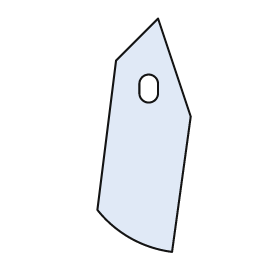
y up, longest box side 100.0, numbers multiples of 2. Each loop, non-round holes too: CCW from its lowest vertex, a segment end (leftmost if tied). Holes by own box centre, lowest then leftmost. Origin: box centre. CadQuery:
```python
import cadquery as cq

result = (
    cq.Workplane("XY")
    .moveTo(12.0, -50.0)
    .lineTo(20.0, 8.0)
    .lineTo(6.0, 50.0)
    .lineTo(-12.0, 32.0)
    .lineTo(-20.0, -32.0)
    .threePointArc((-6.0, -44.0), (12.0, -50.0))
    .close()
    .moveTo(-2.0, 18.0)
    .threePointArc((2.0, 14.0), (6.0, 18.0))
    .lineTo(6.0, 22.0)
    .threePointArc((2.0, 26.0), (-2.0, 22.0))
    .close()
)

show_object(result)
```